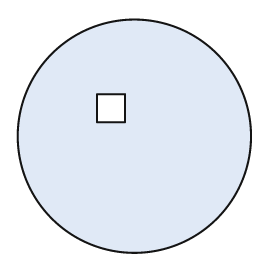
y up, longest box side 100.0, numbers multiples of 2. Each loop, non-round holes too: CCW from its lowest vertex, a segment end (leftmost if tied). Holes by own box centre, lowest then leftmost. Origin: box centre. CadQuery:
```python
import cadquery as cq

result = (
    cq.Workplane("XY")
    .moveTo(0.0, 0.0)
    .circle(50.0)
    .moveTo(-16.0, 6.0)
    .lineTo(-4.0, 6.0)
    .lineTo(-4.0, 18.0)
    .lineTo(-16.0, 18.0)
    .close()
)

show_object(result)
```